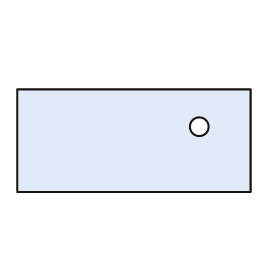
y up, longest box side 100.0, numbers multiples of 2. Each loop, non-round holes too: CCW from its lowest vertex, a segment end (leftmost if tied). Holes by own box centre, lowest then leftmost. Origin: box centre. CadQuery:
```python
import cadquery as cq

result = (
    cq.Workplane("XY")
    .moveTo(-50.0, -22.0)
    .lineTo(50.0, -22.0)
    .lineTo(50.0, 22.0)
    .lineTo(-50.0, 22.0)
    .close()
    .moveTo(28.0, 6.0)
    .circle(4.0)
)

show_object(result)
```